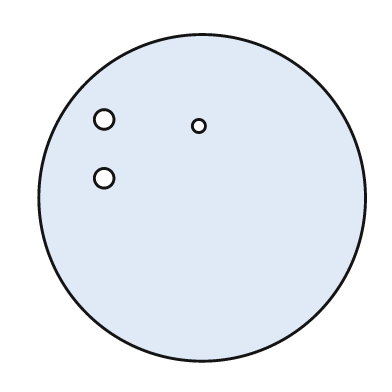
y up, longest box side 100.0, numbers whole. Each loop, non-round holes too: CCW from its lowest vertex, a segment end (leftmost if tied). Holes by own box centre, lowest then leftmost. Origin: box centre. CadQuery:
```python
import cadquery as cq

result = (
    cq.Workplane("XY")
    .moveTo(0.0, 0.0)
    .circle(50.0)
    .moveTo(-30.0, 6.0)
    .circle(3.0)
    .moveTo(-1.0, 22.0)
    .circle(2.0)
    .moveTo(-30.0, 24.0)
    .circle(3.0)
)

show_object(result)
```